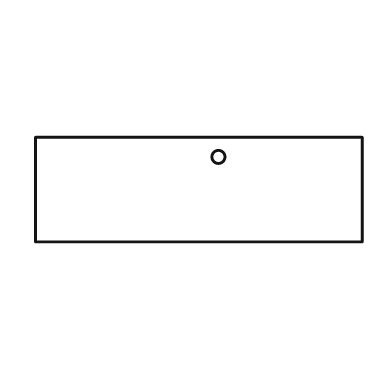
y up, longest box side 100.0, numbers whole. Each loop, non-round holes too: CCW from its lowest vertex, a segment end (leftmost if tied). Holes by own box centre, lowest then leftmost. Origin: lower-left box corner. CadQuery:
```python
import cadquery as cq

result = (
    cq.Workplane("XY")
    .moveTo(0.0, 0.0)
    .lineTo(100.0, 0.0)
    .lineTo(100.0, 32.0)
    .lineTo(0.0, 32.0)
    .close()
    .moveTo(56.0, 26.0)
    .circle(2.0)
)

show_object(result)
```